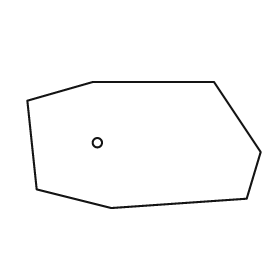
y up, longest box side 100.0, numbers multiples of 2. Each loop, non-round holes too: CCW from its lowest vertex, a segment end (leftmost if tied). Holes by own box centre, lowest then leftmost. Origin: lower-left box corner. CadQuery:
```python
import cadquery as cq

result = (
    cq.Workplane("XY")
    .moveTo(36.0, 0.0)
    .lineTo(94.0, 4.0)
    .lineTo(100.0, 24.0)
    .lineTo(80.0, 54.0)
    .lineTo(28.0, 54.0)
    .lineTo(0.0, 46.0)
    .lineTo(4.0, 8.0)
    .close()
    .moveTo(30.0, 28.0)
    .circle(2.0)
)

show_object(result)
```